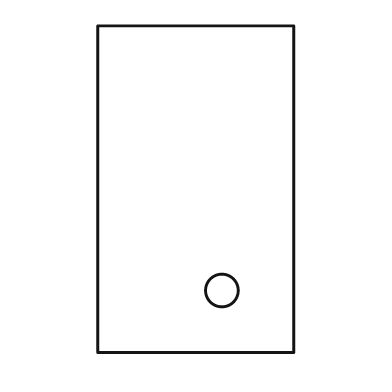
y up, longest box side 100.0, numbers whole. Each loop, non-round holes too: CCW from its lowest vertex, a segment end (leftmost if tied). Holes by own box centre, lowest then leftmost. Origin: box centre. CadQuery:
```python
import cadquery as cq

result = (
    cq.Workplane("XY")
    .moveTo(-30.0, -50.0)
    .lineTo(30.0, -50.0)
    .lineTo(30.0, 50.0)
    .lineTo(-30.0, 50.0)
    .close()
    .moveTo(8.0, -31.0)
    .circle(5.0)
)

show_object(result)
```